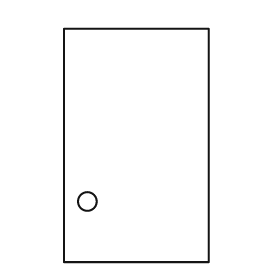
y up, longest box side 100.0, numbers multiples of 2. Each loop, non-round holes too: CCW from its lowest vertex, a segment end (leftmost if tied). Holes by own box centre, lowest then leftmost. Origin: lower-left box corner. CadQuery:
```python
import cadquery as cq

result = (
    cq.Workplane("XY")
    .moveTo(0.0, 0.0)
    .lineTo(62.0, 0.0)
    .lineTo(62.0, 100.0)
    .lineTo(0.0, 100.0)
    .close()
    .moveTo(10.0, 26.0)
    .circle(4.0)
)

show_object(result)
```